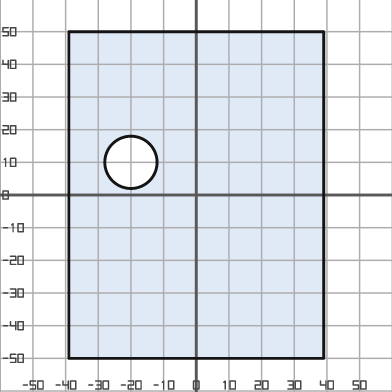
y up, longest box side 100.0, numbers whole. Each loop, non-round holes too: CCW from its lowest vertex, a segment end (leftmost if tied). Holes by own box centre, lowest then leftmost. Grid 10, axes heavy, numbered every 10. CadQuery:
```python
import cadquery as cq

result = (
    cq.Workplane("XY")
    .moveTo(-39.0, -50.0)
    .lineTo(39.0, -50.0)
    .lineTo(39.0, 50.0)
    .lineTo(-39.0, 50.0)
    .close()
    .moveTo(-20.0, 10.0)
    .circle(8.0)
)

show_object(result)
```